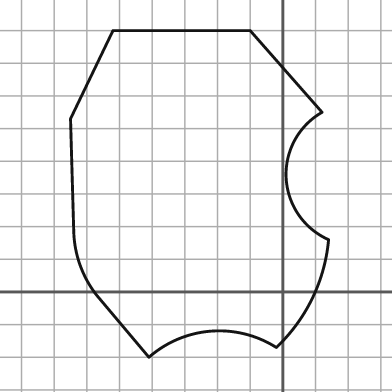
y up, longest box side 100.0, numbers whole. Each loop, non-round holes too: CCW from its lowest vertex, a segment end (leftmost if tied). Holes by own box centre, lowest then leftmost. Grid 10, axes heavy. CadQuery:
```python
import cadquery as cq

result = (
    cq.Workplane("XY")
    .moveTo(-41.0, -20.0)
    .threePointArc((-22.0, -12.0), (-2.0, -17.0))
    .threePointArc((9.0, -2.0), (14.0, 16.0))
    .threePointArc((1.0, 35.0), (12.0, 55.0))
    .lineTo(-10.0, 80.0)
    .lineTo(-52.0, 80.0)
    .lineTo(-65.0, 53.0)
    .lineTo(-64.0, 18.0)
    .threePointArc((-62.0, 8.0), (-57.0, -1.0))
    .close()
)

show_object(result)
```